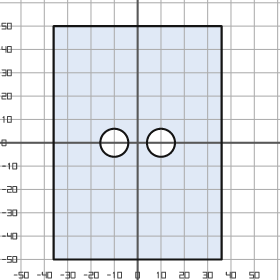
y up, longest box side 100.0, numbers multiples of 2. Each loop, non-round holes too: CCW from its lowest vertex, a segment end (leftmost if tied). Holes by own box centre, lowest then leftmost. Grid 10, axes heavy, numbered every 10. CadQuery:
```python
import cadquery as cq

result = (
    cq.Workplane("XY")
    .moveTo(-36.0, -50.0)
    .lineTo(36.0, -50.0)
    .lineTo(36.0, 50.0)
    .lineTo(-36.0, 50.0)
    .close()
    .moveTo(-10.0, 0.0)
    .circle(6.0)
    .moveTo(10.0, 0.0)
    .circle(6.0)
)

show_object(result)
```